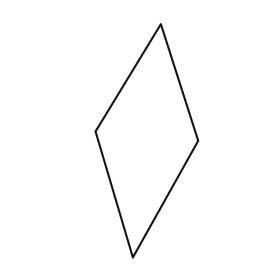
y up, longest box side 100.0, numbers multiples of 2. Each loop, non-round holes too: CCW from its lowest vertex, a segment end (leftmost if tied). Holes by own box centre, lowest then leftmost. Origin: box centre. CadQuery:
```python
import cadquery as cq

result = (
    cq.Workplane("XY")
    .moveTo(-6.0, -50.0)
    .lineTo(22.0, 0.0)
    .lineTo(6.0, 50.0)
    .lineTo(-22.0, 4.0)
    .close()
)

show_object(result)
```